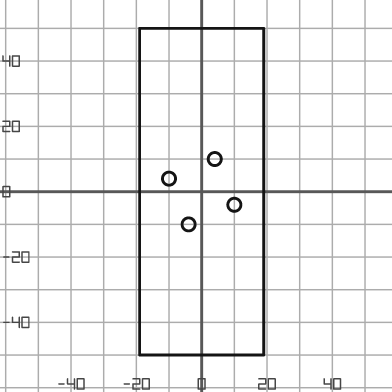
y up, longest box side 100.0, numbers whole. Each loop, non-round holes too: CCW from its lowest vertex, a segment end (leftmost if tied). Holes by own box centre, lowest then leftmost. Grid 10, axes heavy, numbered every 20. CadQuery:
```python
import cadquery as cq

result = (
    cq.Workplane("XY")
    .moveTo(-19.0, -50.0)
    .lineTo(19.0, -50.0)
    .lineTo(19.0, 50.0)
    .lineTo(-19.0, 50.0)
    .close()
    .moveTo(-4.0, -10.0)
    .circle(2.0)
    .moveTo(10.0, -4.0)
    .circle(2.0)
    .moveTo(-10.0, 4.0)
    .circle(2.0)
    .moveTo(4.0, 10.0)
    .circle(2.0)
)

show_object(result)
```